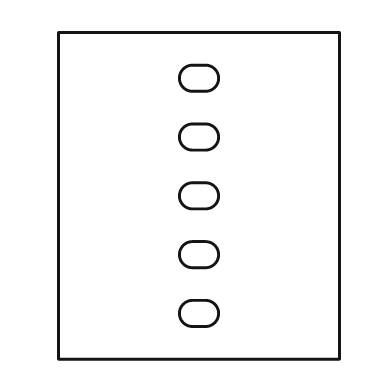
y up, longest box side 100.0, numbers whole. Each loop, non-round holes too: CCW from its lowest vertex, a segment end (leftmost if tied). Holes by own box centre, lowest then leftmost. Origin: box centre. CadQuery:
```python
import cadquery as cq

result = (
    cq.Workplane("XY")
    .moveTo(-43.0, -50.0)
    .lineTo(43.0, -50.0)
    .lineTo(43.0, 50.0)
    .lineTo(-43.0, 50.0)
    .close()
    .moveTo(-2.0, -40.0)
    .lineTo(2.0, -40.0)
    .threePointArc((6.0, -36.0), (2.0, -32.0))
    .lineTo(-2.0, -32.0)
    .threePointArc((-6.0, -36.0), (-2.0, -40.0))
    .close()
    .moveTo(-2.0, -22.0)
    .lineTo(2.0, -22.0)
    .threePointArc((6.0, -18.0), (2.0, -14.0))
    .lineTo(-2.0, -14.0)
    .threePointArc((-6.0, -18.0), (-2.0, -22.0))
    .close()
    .moveTo(-2.0, -4.0)
    .lineTo(2.0, -4.0)
    .threePointArc((6.0, 0.0), (2.0, 4.0))
    .lineTo(-2.0, 4.0)
    .threePointArc((-6.0, 0.0), (-2.0, -4.0))
    .close()
    .moveTo(-2.0, 14.0)
    .lineTo(2.0, 14.0)
    .threePointArc((6.0, 18.0), (2.0, 22.0))
    .lineTo(-2.0, 22.0)
    .threePointArc((-6.0, 18.0), (-2.0, 14.0))
    .close()
    .moveTo(-2.0, 32.0)
    .lineTo(2.0, 32.0)
    .threePointArc((6.0, 36.0), (2.0, 40.0))
    .lineTo(-2.0, 40.0)
    .threePointArc((-6.0, 36.0), (-2.0, 32.0))
    .close()
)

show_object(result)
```